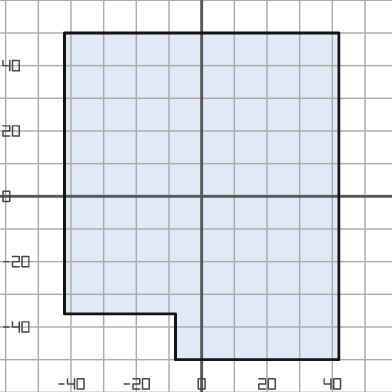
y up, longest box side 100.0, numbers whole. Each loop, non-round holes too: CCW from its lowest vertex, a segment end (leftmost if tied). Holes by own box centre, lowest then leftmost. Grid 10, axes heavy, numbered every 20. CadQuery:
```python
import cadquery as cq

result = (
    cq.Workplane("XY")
    .moveTo(-8.0, -50.0)
    .lineTo(42.0, -50.0)
    .lineTo(42.0, 50.0)
    .lineTo(-42.0, 50.0)
    .lineTo(-42.0, -36.0)
    .lineTo(-8.0, -36.0)
    .close()
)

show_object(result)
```